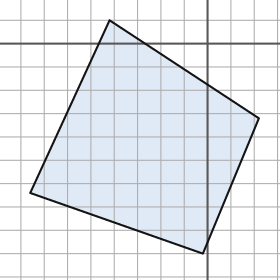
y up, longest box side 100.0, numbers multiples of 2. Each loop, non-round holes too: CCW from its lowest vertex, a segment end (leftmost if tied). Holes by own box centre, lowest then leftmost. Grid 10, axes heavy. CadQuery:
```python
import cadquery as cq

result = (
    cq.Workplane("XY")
    .moveTo(-2.0, -90.0)
    .lineTo(22.0, -32.0)
    .lineTo(-42.0, 10.0)
    .lineTo(-76.0, -64.0)
    .close()
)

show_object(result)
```